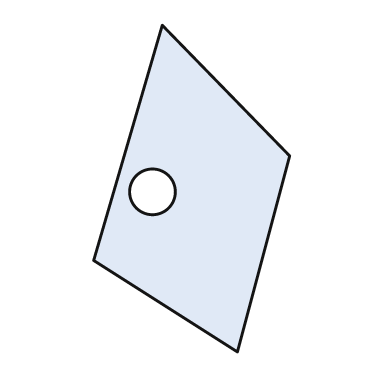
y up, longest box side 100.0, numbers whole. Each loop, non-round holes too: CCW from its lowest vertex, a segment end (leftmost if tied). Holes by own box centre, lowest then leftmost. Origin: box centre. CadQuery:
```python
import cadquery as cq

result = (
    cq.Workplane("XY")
    .moveTo(14.0, -50.0)
    .lineTo(30.0, 10.0)
    .lineTo(-9.0, 50.0)
    .lineTo(-30.0, -22.0)
    .close()
    .moveTo(-12.0, -1.0)
    .circle(7.0)
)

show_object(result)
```